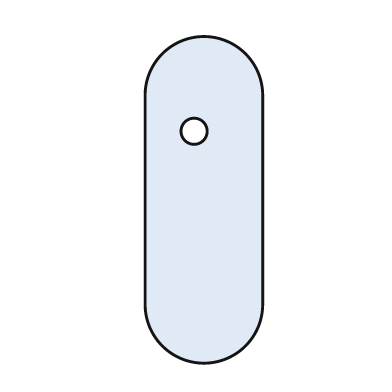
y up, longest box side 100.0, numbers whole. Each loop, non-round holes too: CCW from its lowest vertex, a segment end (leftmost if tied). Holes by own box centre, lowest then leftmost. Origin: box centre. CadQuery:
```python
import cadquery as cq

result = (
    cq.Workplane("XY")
    .moveTo(-18.0, -32.0)
    .threePointArc((0.0, -50.0), (18.0, -32.0))
    .lineTo(18.0, 32.0)
    .threePointArc((0.0, 50.0), (-18.0, 32.0))
    .close()
    .moveTo(-3.0, 21.0)
    .circle(4.0)
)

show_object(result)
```